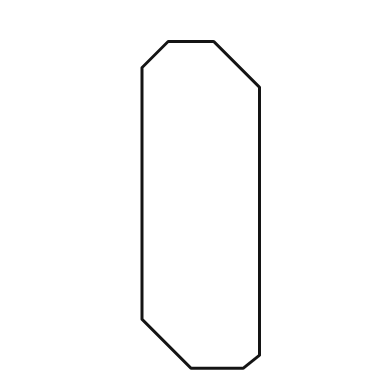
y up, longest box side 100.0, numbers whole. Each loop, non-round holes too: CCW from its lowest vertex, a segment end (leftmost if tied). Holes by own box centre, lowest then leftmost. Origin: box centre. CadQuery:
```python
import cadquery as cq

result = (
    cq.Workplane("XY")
    .moveTo(-3.0, -50.0)
    .lineTo(13.0, -50.0)
    .lineTo(18.0, -46.0)
    .lineTo(18.0, 36.0)
    .lineTo(4.0, 50.0)
    .lineTo(-10.0, 50.0)
    .lineTo(-18.0, 42.0)
    .lineTo(-18.0, -35.0)
    .close()
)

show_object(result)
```